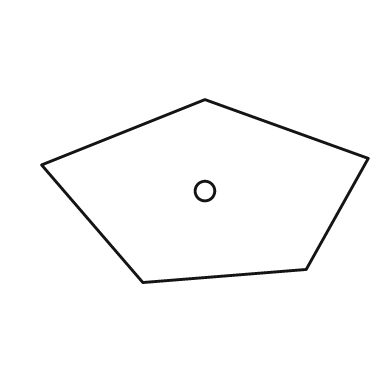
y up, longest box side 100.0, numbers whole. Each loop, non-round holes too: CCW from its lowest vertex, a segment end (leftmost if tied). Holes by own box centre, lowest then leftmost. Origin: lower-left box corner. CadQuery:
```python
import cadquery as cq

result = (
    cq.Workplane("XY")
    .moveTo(31.0, 0.0)
    .lineTo(81.0, 4.0)
    .lineTo(100.0, 38.0)
    .lineTo(50.0, 56.0)
    .lineTo(0.0, 36.0)
    .close()
    .moveTo(50.0, 28.0)
    .circle(3.0)
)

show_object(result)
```